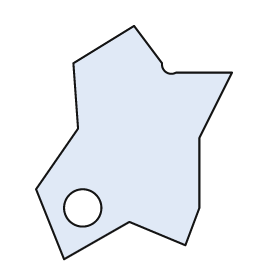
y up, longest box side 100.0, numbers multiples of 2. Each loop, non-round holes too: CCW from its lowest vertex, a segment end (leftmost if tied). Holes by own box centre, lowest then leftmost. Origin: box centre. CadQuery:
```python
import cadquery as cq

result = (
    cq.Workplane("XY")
    .moveTo(-30.0, -50.0)
    .lineTo(-2.0, -34.0)
    .lineTo(22.0, -44.0)
    .lineTo(28.0, -28.0)
    .lineTo(28.0, 2.0)
    .lineTo(42.0, 30.0)
    .lineTo(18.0, 30.0)
    .threePointArc((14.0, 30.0), (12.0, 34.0))
    .lineTo(0.0, 50.0)
    .lineTo(-26.0, 34.0)
    .lineTo(-24.0, 6.0)
    .lineTo(-42.0, -20.0)
    .close()
    .moveTo(-22.0, -28.0)
    .circle(8.0)
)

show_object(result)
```